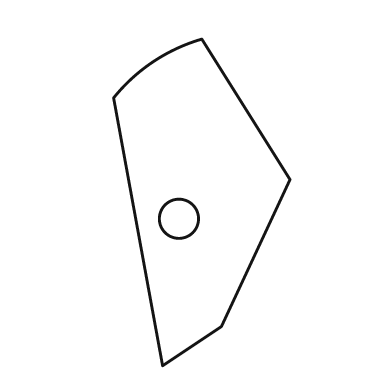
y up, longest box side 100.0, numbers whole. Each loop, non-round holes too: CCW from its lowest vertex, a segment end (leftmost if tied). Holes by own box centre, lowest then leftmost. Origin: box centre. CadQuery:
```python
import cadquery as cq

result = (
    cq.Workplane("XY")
    .moveTo(-12.0, -50.0)
    .lineTo(6.0, -38.0)
    .lineTo(27.0, 7.0)
    .lineTo(0.0, 50.0)
    .threePointArc((-15.0, 43.0), (-27.0, 32.0))
    .close()
    .moveTo(-7.0, -5.0)
    .circle(6.0)
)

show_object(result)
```